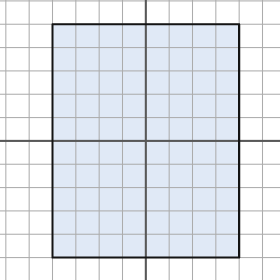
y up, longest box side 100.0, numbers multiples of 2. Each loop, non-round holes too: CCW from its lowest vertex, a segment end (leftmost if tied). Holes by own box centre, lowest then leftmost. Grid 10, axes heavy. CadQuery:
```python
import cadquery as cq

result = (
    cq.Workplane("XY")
    .moveTo(-40.0, -50.0)
    .lineTo(40.0, -50.0)
    .lineTo(40.0, 50.0)
    .lineTo(-40.0, 50.0)
    .close()
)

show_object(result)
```